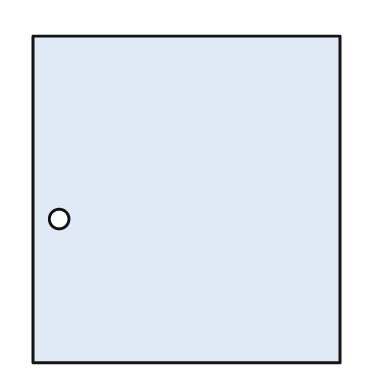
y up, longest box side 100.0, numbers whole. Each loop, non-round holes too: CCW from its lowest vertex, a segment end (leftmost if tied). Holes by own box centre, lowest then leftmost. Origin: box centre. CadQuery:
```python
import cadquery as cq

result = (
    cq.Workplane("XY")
    .moveTo(-47.0, -50.0)
    .lineTo(47.0, -50.0)
    .lineTo(47.0, 50.0)
    .lineTo(-47.0, 50.0)
    .close()
    .moveTo(-39.0, -6.0)
    .circle(3.0)
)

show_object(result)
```